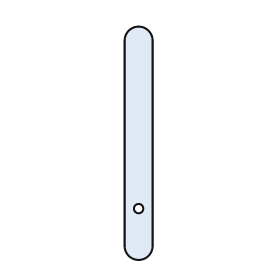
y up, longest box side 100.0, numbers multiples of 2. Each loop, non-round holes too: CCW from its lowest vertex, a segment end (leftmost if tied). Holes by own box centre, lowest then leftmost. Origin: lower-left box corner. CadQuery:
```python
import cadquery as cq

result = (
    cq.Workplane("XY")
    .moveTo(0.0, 6.0)
    .threePointArc((6.0, 0.0), (12.0, 6.0))
    .lineTo(12.0, 94.0)
    .threePointArc((6.0, 100.0), (0.0, 94.0))
    .close()
    .moveTo(6.0, 22.0)
    .circle(2.0)
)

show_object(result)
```